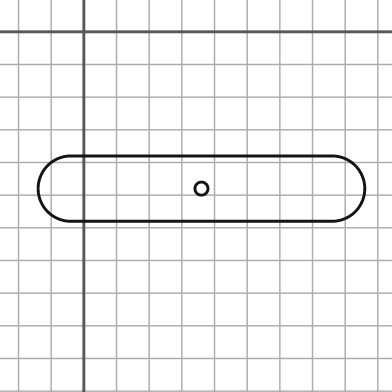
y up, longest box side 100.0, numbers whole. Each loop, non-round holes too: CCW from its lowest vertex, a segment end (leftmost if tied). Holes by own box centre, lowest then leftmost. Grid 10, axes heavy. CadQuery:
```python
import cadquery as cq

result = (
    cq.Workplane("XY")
    .moveTo(-4.0, -58.0)
    .lineTo(76.0, -58.0)
    .threePointArc((86.0, -48.0), (76.0, -38.0))
    .lineTo(-4.0, -38.0)
    .threePointArc((-14.0, -48.0), (-4.0, -58.0))
    .close()
    .moveTo(36.0, -48.0)
    .circle(2.0)
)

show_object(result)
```